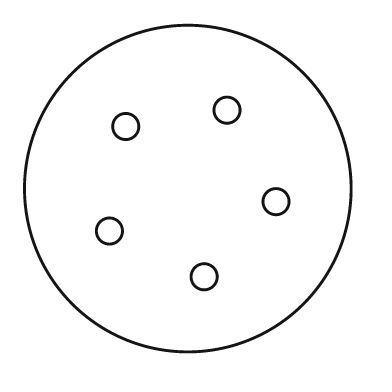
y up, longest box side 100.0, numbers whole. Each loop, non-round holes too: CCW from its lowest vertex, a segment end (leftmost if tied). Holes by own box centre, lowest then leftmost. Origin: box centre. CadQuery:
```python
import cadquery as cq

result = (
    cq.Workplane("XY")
    .moveTo(0.0, 0.0)
    .circle(50.0)
    .moveTo(5.0, -27.0)
    .circle(4.0)
    .moveTo(-24.0, -13.0)
    .circle(4.0)
    .moveTo(27.0, -4.0)
    .circle(4.0)
    .moveTo(-19.0, 19.0)
    .circle(4.0)
    .moveTo(12.0, 24.0)
    .circle(4.0)
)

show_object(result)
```